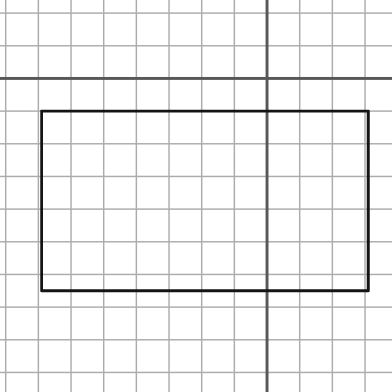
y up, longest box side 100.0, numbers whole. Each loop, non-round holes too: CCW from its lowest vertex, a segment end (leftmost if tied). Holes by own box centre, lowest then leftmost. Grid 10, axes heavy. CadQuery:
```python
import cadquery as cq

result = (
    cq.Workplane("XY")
    .moveTo(-69.0, -65.0)
    .lineTo(31.0, -65.0)
    .lineTo(31.0, -10.0)
    .lineTo(-69.0, -10.0)
    .close()
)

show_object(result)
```